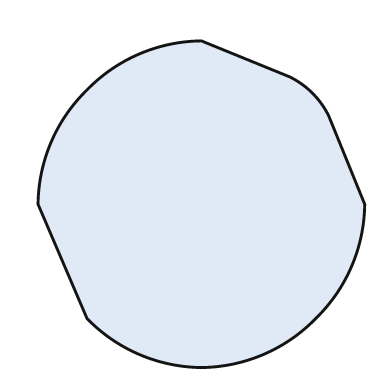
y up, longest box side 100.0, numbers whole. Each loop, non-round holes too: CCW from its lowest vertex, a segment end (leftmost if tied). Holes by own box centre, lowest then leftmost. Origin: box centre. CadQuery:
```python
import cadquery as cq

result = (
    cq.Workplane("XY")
    .moveTo(0.0, -50.0)
    .threePointArc((19.0, -46.0), (35.0, -35.0))
    .threePointArc((46.0, -19.0), (50.0, 0.0))
    .lineTo(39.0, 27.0)
    .threePointArc((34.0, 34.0), (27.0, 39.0))
    .lineTo(0.0, 50.0)
    .threePointArc((-19.0, 46.0), (-35.0, 35.0))
    .threePointArc((-46.0, 19.0), (-50.0, 0.0))
    .lineTo(-35.0, -35.0)
    .threePointArc((-19.0, -46.0), (0.0, -50.0))
    .close()
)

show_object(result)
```